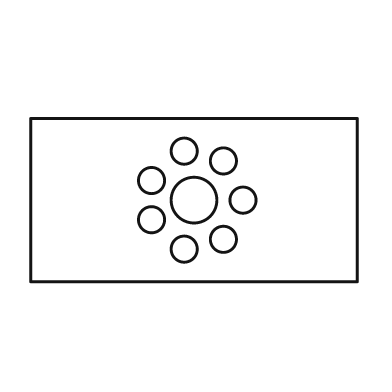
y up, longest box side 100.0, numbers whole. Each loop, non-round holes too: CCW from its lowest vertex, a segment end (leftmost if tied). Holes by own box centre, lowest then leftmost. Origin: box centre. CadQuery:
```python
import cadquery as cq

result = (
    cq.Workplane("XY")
    .moveTo(-50.0, -25.0)
    .lineTo(50.0, -25.0)
    .lineTo(50.0, 25.0)
    .lineTo(-50.0, 25.0)
    .close()
    .moveTo(-3.0, -15.0)
    .circle(4.0)
    .moveTo(9.0, -12.0)
    .circle(4.0)
    .moveTo(-13.0, -6.0)
    .circle(4.0)
    .moveTo(0.0, 0.0)
    .circle(7.0)
    .moveTo(15.0, 0.0)
    .circle(4.0)
    .moveTo(-13.0, 6.0)
    .circle(4.0)
    .moveTo(9.0, 12.0)
    .circle(4.0)
    .moveTo(-3.0, 15.0)
    .circle(4.0)
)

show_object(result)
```